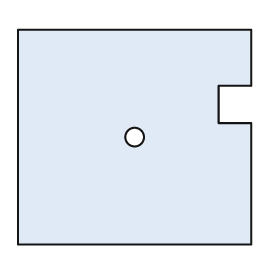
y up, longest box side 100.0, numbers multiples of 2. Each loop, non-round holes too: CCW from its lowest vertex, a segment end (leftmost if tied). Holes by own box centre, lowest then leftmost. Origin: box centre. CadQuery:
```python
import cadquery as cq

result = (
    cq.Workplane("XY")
    .moveTo(-50.0, -46.0)
    .lineTo(50.0, -46.0)
    .lineTo(50.0, 6.0)
    .lineTo(36.0, 6.0)
    .lineTo(36.0, 22.0)
    .lineTo(50.0, 22.0)
    .lineTo(50.0, 46.0)
    .lineTo(-50.0, 46.0)
    .close()
    .moveTo(0.0, 0.0)
    .circle(4.0)
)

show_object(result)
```